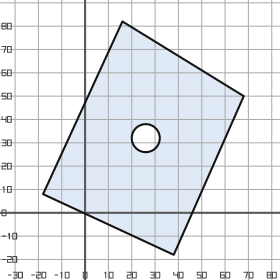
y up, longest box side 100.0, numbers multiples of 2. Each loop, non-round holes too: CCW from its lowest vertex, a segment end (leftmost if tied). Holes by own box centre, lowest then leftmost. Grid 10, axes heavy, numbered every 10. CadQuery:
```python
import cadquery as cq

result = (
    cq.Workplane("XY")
    .moveTo(38.0, -18.0)
    .lineTo(68.0, 50.0)
    .lineTo(16.0, 82.0)
    .lineTo(-18.0, 8.0)
    .close()
    .moveTo(26.0, 32.0)
    .circle(6.0)
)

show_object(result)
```